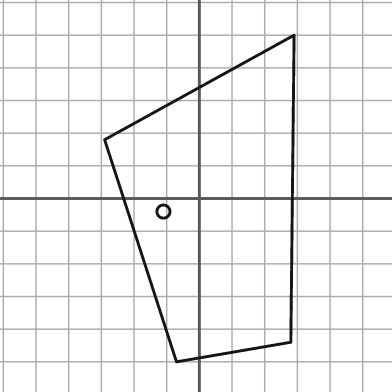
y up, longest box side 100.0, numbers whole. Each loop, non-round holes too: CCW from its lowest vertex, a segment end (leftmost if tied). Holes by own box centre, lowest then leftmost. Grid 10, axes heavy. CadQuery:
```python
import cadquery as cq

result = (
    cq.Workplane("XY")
    .moveTo(-7.0, -50.0)
    .lineTo(28.0, -44.0)
    .lineTo(29.0, 50.0)
    .lineTo(-29.0, 18.0)
    .close()
    .moveTo(-11.0, -4.0)
    .circle(2.0)
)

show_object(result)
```